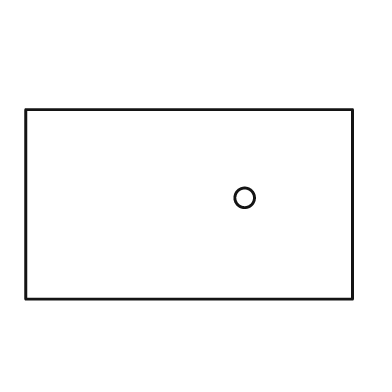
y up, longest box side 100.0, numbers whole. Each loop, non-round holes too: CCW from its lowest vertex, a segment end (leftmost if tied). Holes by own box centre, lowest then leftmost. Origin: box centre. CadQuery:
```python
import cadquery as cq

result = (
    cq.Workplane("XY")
    .moveTo(-50.0, -29.0)
    .lineTo(50.0, -29.0)
    .lineTo(50.0, 29.0)
    .lineTo(-50.0, 29.0)
    .close()
    .moveTo(17.0, 2.0)
    .circle(3.0)
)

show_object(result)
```